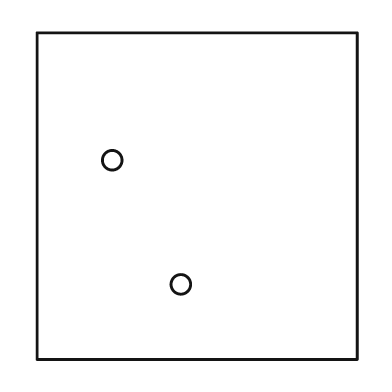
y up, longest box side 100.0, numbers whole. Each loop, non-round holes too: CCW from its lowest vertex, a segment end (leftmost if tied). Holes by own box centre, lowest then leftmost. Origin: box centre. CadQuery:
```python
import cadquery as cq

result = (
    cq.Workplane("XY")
    .moveTo(-49.0, -50.0)
    .lineTo(49.0, -50.0)
    .lineTo(49.0, 50.0)
    .lineTo(-49.0, 50.0)
    .close()
    .moveTo(-5.0, -27.0)
    .circle(3.0)
    .moveTo(-26.0, 11.0)
    .circle(3.0)
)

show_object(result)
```